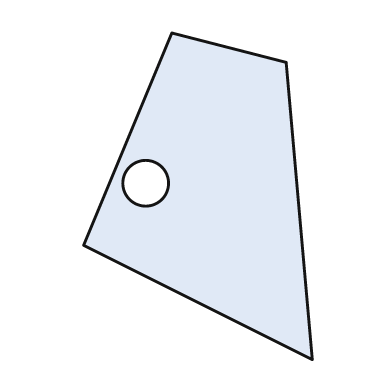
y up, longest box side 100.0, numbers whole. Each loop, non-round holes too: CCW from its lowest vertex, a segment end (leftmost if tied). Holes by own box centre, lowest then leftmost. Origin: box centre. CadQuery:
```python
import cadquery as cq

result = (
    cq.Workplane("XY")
    .moveTo(35.0, -50.0)
    .lineTo(27.0, 41.0)
    .lineTo(-8.0, 50.0)
    .lineTo(-35.0, -15.0)
    .close()
    .moveTo(-16.0, 4.0)
    .circle(7.0)
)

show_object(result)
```